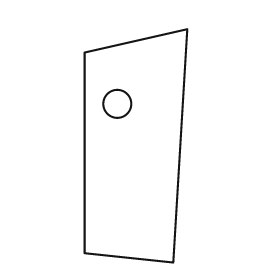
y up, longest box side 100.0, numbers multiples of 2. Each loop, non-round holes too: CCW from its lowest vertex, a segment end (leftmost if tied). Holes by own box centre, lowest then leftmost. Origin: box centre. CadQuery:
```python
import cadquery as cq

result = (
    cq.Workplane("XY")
    .moveTo(16.0, -50.0)
    .lineTo(22.0, 50.0)
    .lineTo(-22.0, 40.0)
    .lineTo(-22.0, -46.0)
    .close()
    .moveTo(-8.0, 18.0)
    .circle(6.0)
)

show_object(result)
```